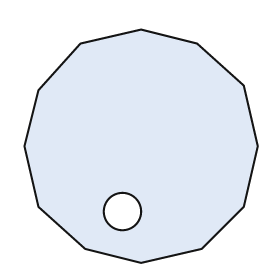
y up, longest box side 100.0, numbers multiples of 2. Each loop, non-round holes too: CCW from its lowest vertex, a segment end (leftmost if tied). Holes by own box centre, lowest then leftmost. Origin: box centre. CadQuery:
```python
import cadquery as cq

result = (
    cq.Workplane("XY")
    .moveTo(0.0, -50.0)
    .lineTo(26.0, -44.0)
    .lineTo(44.0, -26.0)
    .lineTo(50.0, 0.0)
    .lineTo(44.0, 26.0)
    .lineTo(24.0, 44.0)
    .lineTo(0.0, 50.0)
    .lineTo(-26.0, 44.0)
    .lineTo(-44.0, 24.0)
    .lineTo(-50.0, 0.0)
    .lineTo(-44.0, -26.0)
    .lineTo(-24.0, -44.0)
    .close()
    .moveTo(-8.0, -28.0)
    .circle(8.0)
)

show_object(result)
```